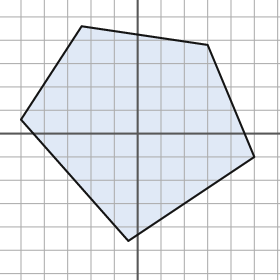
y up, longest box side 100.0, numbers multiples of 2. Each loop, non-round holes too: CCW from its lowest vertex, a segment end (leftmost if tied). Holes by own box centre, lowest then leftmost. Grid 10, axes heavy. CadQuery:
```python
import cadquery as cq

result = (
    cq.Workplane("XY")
    .moveTo(-4.0, -46.0)
    .lineTo(50.0, -10.0)
    .lineTo(30.0, 38.0)
    .lineTo(-24.0, 46.0)
    .lineTo(-50.0, 6.0)
    .close()
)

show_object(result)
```